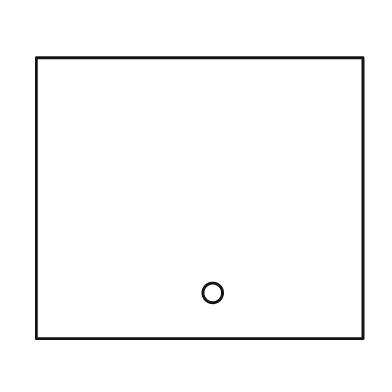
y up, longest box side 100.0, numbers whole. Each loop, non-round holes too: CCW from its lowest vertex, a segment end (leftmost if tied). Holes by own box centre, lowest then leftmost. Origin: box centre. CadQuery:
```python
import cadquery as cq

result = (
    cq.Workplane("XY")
    .moveTo(-50.0, -43.0)
    .lineTo(50.0, -43.0)
    .lineTo(50.0, 43.0)
    .lineTo(-50.0, 43.0)
    .close()
    .moveTo(4.0, -29.0)
    .circle(3.0)
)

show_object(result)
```